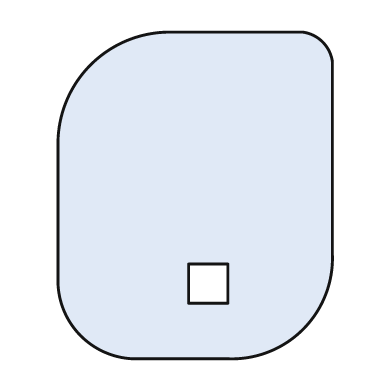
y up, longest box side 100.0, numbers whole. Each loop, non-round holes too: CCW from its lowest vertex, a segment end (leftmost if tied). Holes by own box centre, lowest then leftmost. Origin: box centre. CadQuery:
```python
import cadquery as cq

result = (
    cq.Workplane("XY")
    .moveTo(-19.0, -50.0)
    .lineTo(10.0, -50.0)
    .threePointArc((33.0, -41.0), (42.0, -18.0))
    .lineTo(42.0, 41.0)
    .threePointArc((39.0, 47.0), (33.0, 50.0))
    .lineTo(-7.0, 50.0)
    .threePointArc((-32.0, 40.0), (-42.0, 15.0))
    .lineTo(-42.0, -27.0)
    .threePointArc((-35.0, -43.0), (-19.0, -50.0))
    .close()
    .moveTo(-2.0, -33.0)
    .lineTo(10.0, -33.0)
    .lineTo(10.0, -21.0)
    .lineTo(-2.0, -21.0)
    .close()
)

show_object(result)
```